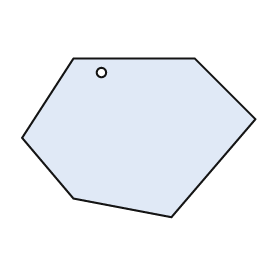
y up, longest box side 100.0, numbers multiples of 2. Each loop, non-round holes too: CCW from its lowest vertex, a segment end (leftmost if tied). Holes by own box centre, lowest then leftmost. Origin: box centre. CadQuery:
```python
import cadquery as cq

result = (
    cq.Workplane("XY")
    .moveTo(14.0, -34.0)
    .lineTo(50.0, 8.0)
    .lineTo(24.0, 34.0)
    .lineTo(-28.0, 34.0)
    .lineTo(-50.0, 0.0)
    .lineTo(-28.0, -26.0)
    .close()
    .moveTo(-16.0, 28.0)
    .circle(2.0)
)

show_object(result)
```